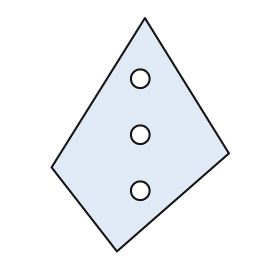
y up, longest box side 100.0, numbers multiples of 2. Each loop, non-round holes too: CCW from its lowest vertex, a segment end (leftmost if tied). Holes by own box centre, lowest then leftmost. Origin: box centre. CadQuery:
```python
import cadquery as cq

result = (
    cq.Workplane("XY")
    .moveTo(-10.0, -50.0)
    .lineTo(38.0, -8.0)
    .lineTo(2.0, 50.0)
    .lineTo(-38.0, -14.0)
    .close()
    .moveTo(0.0, -24.0)
    .circle(4.0)
    .moveTo(0.0, 0.0)
    .circle(4.0)
    .moveTo(0.0, 24.0)
    .circle(4.0)
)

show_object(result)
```